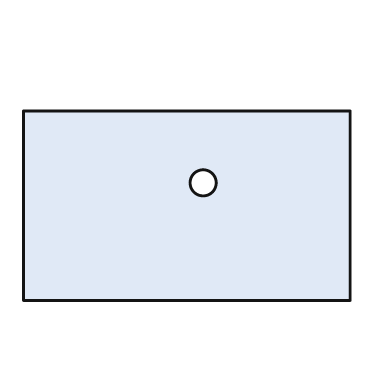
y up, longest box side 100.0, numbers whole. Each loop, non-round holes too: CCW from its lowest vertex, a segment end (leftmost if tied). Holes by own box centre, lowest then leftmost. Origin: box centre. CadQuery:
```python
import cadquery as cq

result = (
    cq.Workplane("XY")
    .moveTo(-50.0, -29.0)
    .lineTo(50.0, -29.0)
    .lineTo(50.0, 29.0)
    .lineTo(-50.0, 29.0)
    .close()
    .moveTo(5.0, 7.0)
    .circle(4.0)
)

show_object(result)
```